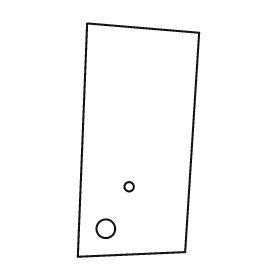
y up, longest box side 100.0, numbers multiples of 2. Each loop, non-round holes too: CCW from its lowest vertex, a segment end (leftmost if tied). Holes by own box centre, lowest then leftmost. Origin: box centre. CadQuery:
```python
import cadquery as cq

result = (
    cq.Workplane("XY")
    .moveTo(-26.0, -50.0)
    .lineTo(20.0, -48.0)
    .lineTo(26.0, 46.0)
    .lineTo(-22.0, 50.0)
    .close()
    .moveTo(-14.0, -38.0)
    .circle(4.0)
    .moveTo(-4.0, -20.0)
    .circle(2.0)
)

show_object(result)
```